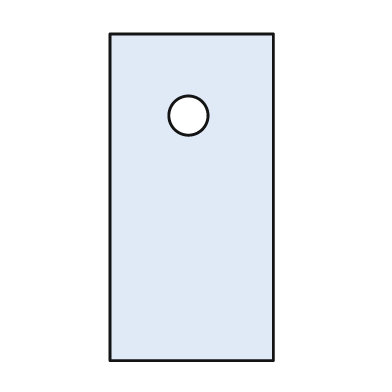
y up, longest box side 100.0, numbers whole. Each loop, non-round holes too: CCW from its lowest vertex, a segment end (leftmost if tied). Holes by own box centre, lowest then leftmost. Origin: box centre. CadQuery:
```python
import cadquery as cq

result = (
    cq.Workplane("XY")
    .moveTo(-25.0, -50.0)
    .lineTo(25.0, -50.0)
    .lineTo(25.0, 50.0)
    .lineTo(-25.0, 50.0)
    .close()
    .moveTo(-1.0, 25.0)
    .circle(6.0)
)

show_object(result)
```